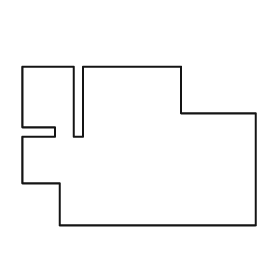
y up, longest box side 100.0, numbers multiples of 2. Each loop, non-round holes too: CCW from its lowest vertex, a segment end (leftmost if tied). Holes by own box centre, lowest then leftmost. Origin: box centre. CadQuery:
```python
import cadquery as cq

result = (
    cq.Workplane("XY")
    .moveTo(-34.0, -34.0)
    .lineTo(50.0, -34.0)
    .lineTo(50.0, 14.0)
    .lineTo(18.0, 14.0)
    .lineTo(18.0, 34.0)
    .lineTo(-24.0, 34.0)
    .lineTo(-24.0, 4.0)
    .lineTo(-28.0, 4.0)
    .lineTo(-28.0, 34.0)
    .lineTo(-50.0, 34.0)
    .lineTo(-50.0, 8.0)
    .lineTo(-36.0, 8.0)
    .lineTo(-36.0, 4.0)
    .lineTo(-50.0, 4.0)
    .lineTo(-50.0, -16.0)
    .lineTo(-34.0, -16.0)
    .close()
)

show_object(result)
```